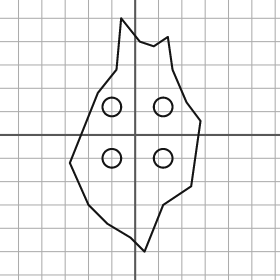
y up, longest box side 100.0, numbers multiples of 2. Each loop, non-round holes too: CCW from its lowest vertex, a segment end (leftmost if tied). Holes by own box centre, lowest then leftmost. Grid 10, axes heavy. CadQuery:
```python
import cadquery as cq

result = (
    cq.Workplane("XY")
    .moveTo(4.0, -50.0)
    .lineTo(12.0, -30.0)
    .lineTo(24.0, -22.0)
    .lineTo(28.0, 6.0)
    .lineTo(22.0, 14.0)
    .lineTo(16.0, 28.0)
    .lineTo(14.0, 42.0)
    .lineTo(8.0, 38.0)
    .lineTo(2.0, 40.0)
    .lineTo(-6.0, 50.0)
    .lineTo(-8.0, 28.0)
    .lineTo(-16.0, 18.0)
    .lineTo(-28.0, -12.0)
    .lineTo(-20.0, -30.0)
    .lineTo(-12.0, -38.0)
    .lineTo(-2.0, -44.0)
    .close()
    .moveTo(-10.0, -10.0)
    .circle(4.0)
    .moveTo(12.0, -10.0)
    .circle(4.0)
    .moveTo(-10.0, 12.0)
    .circle(4.0)
    .moveTo(12.0, 12.0)
    .circle(4.0)
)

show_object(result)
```